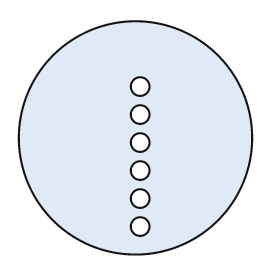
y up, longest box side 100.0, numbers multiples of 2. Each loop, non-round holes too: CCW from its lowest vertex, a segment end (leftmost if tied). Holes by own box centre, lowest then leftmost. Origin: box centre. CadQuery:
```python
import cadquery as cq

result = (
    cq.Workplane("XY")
    .moveTo(0.0, 0.0)
    .circle(50.0)
    .moveTo(2.0, -38.0)
    .circle(4.0)
    .moveTo(2.0, -26.0)
    .circle(4.0)
    .moveTo(2.0, -14.0)
    .circle(4.0)
    .moveTo(2.0, -2.0)
    .circle(4.0)
    .moveTo(2.0, 10.0)
    .circle(4.0)
    .moveTo(2.0, 22.0)
    .circle(4.0)
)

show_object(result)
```